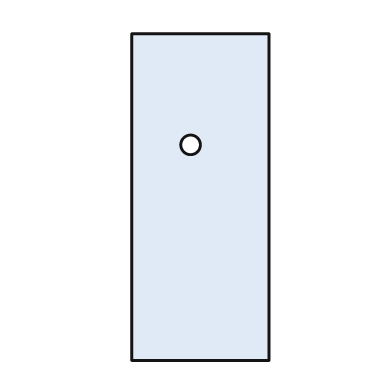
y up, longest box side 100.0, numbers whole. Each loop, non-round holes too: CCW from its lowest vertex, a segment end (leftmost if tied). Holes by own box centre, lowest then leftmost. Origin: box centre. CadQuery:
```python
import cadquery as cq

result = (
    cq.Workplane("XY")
    .moveTo(-21.0, -50.0)
    .lineTo(21.0, -50.0)
    .lineTo(21.0, 50.0)
    .lineTo(-21.0, 50.0)
    .close()
    .moveTo(-3.0, 16.0)
    .circle(3.0)
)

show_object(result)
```